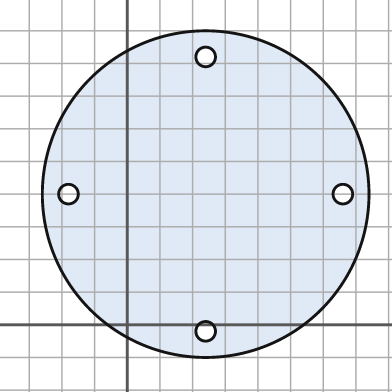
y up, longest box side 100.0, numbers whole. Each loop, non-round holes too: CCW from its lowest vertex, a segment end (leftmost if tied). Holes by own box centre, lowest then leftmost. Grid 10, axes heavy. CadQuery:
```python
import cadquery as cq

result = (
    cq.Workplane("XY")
    .moveTo(24.0, 40.0)
    .circle(50.0)
    .moveTo(24.0, -2.0)
    .circle(3.0)
    .moveTo(-18.0, 40.0)
    .circle(3.0)
    .moveTo(66.0, 40.0)
    .circle(3.0)
    .moveTo(24.0, 82.0)
    .circle(3.0)
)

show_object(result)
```